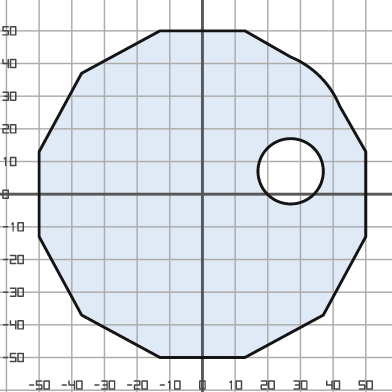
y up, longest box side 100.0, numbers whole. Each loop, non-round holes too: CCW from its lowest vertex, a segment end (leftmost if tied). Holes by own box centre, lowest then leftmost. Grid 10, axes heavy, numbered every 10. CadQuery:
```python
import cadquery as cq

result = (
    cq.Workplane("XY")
    .moveTo(-13.0, -50.0)
    .lineTo(13.0, -50.0)
    .lineTo(37.0, -37.0)
    .lineTo(50.0, -13.0)
    .lineTo(50.0, 13.0)
    .lineTo(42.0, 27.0)
    .threePointArc((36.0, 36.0), (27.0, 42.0))
    .lineTo(13.0, 50.0)
    .lineTo(-13.0, 50.0)
    .lineTo(-37.0, 37.0)
    .lineTo(-50.0, 13.0)
    .lineTo(-50.0, -13.0)
    .lineTo(-37.0, -37.0)
    .close()
    .moveTo(27.0, 7.0)
    .circle(10.0)
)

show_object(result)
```